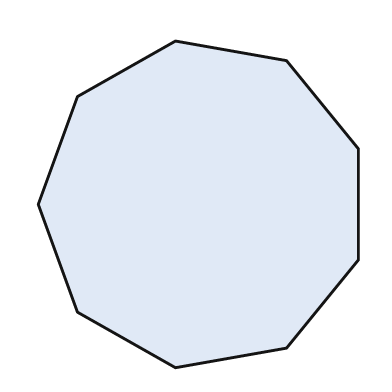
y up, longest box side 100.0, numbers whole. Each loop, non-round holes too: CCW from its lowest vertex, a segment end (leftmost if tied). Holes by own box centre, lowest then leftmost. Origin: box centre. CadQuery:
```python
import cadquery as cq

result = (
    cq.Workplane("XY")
    .moveTo(-7.0, -50.0)
    .lineTo(27.0, -44.0)
    .lineTo(49.0, -17.0)
    .lineTo(49.0, 17.0)
    .lineTo(27.0, 44.0)
    .lineTo(-7.0, 50.0)
    .lineTo(-37.0, 33.0)
    .lineTo(-49.0, 0.0)
    .lineTo(-37.0, -33.0)
    .close()
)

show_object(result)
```